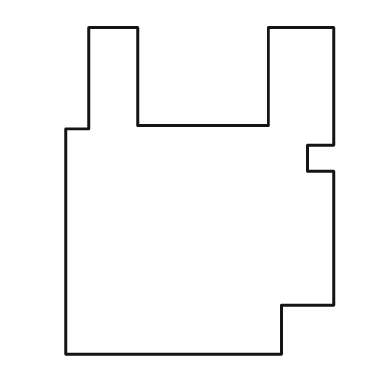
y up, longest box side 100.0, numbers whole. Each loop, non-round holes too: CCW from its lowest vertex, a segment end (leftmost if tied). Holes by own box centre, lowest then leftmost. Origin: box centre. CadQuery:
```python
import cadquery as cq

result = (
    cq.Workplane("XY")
    .moveTo(-41.0, -50.0)
    .lineTo(25.0, -50.0)
    .lineTo(25.0, -35.0)
    .lineTo(41.0, -35.0)
    .lineTo(41.0, 6.0)
    .lineTo(33.0, 6.0)
    .lineTo(33.0, 14.0)
    .lineTo(41.0, 14.0)
    .lineTo(41.0, 50.0)
    .lineTo(21.0, 50.0)
    .lineTo(21.0, 20.0)
    .lineTo(-19.0, 20.0)
    .lineTo(-19.0, 50.0)
    .lineTo(-34.0, 50.0)
    .lineTo(-34.0, 19.0)
    .lineTo(-41.0, 19.0)
    .close()
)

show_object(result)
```